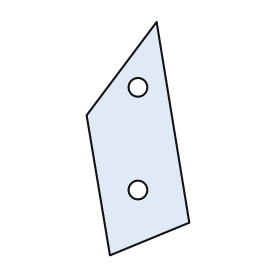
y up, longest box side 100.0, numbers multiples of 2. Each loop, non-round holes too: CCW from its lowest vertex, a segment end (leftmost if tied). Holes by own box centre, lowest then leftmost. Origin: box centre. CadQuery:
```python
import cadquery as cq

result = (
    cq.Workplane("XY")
    .moveTo(-12.0, -50.0)
    .lineTo(22.0, -36.0)
    .lineTo(8.0, 50.0)
    .lineTo(-22.0, 10.0)
    .close()
    .moveTo(0.0, -22.0)
    .circle(4.0)
    .moveTo(0.0, 22.0)
    .circle(4.0)
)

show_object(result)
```